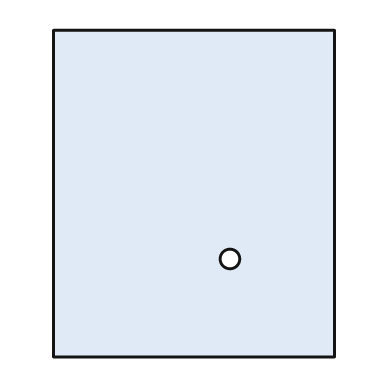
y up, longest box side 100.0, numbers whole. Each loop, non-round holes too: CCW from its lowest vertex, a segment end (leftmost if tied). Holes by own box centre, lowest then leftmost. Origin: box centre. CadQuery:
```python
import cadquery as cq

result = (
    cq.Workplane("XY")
    .moveTo(-43.0, -50.0)
    .lineTo(43.0, -50.0)
    .lineTo(43.0, 50.0)
    .lineTo(-43.0, 50.0)
    .close()
    .moveTo(11.0, -20.0)
    .circle(3.0)
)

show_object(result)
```